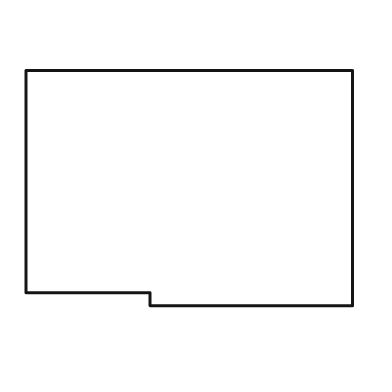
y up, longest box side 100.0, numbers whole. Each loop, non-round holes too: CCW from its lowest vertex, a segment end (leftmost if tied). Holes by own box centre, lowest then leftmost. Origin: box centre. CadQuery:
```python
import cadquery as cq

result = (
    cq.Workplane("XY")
    .moveTo(-12.0, -36.0)
    .lineTo(50.0, -36.0)
    .lineTo(50.0, 36.0)
    .lineTo(-50.0, 36.0)
    .lineTo(-50.0, -32.0)
    .lineTo(-12.0, -32.0)
    .close()
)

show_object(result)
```